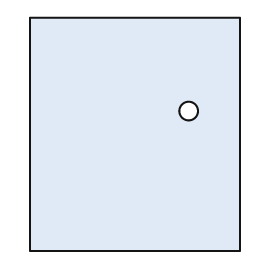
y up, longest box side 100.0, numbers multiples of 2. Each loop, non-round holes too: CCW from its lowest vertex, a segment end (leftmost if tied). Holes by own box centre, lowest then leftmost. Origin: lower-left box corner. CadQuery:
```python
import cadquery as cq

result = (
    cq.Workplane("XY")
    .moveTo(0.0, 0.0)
    .lineTo(90.0, 0.0)
    .lineTo(90.0, 100.0)
    .lineTo(0.0, 100.0)
    .close()
    .moveTo(68.0, 60.0)
    .circle(4.0)
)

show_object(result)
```